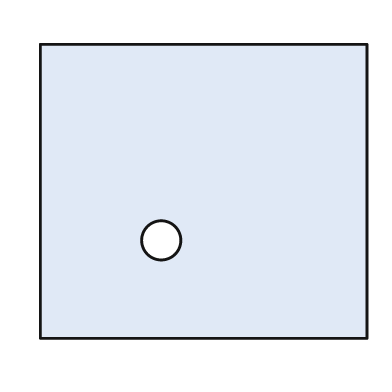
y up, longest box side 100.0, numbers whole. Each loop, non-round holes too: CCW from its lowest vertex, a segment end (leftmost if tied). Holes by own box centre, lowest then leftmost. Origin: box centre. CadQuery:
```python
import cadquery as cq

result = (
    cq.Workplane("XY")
    .moveTo(-50.0, -45.0)
    .lineTo(50.0, -45.0)
    .lineTo(50.0, 45.0)
    .lineTo(-50.0, 45.0)
    .close()
    .moveTo(-13.0, -15.0)
    .circle(6.0)
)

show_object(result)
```